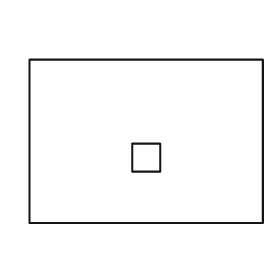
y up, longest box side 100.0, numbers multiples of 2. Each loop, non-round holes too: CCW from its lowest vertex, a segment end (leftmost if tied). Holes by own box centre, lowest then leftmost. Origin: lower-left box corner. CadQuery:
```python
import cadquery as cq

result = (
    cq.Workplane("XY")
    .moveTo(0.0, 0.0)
    .lineTo(100.0, 0.0)
    .lineTo(100.0, 70.0)
    .lineTo(0.0, 70.0)
    .close()
    .moveTo(44.0, 22.0)
    .lineTo(56.0, 22.0)
    .lineTo(56.0, 34.0)
    .lineTo(44.0, 34.0)
    .close()
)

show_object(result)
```